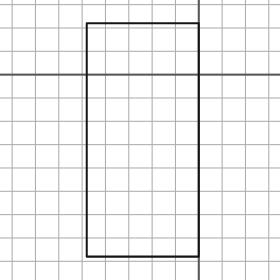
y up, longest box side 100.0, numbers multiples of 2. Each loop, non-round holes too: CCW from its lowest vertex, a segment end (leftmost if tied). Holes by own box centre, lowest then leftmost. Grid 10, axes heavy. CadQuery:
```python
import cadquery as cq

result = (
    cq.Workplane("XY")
    .moveTo(-48.0, -78.0)
    .lineTo(0.0, -78.0)
    .lineTo(0.0, 22.0)
    .lineTo(-48.0, 22.0)
    .close()
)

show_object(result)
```